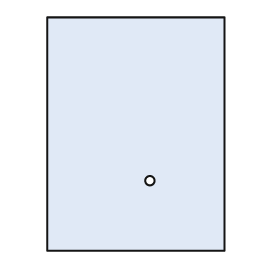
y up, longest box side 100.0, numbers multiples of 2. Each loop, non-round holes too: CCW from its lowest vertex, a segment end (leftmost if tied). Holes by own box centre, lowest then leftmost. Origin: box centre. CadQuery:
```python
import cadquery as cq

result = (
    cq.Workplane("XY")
    .moveTo(-38.0, -50.0)
    .lineTo(38.0, -50.0)
    .lineTo(38.0, 50.0)
    .lineTo(-38.0, 50.0)
    .close()
    .moveTo(6.0, -20.0)
    .circle(2.0)
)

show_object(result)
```